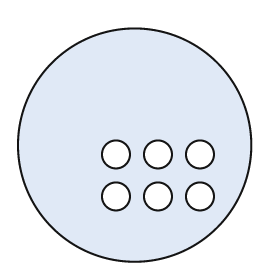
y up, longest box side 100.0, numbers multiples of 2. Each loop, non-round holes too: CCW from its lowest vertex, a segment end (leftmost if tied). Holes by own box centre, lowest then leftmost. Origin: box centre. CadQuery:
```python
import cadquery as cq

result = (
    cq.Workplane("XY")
    .moveTo(0.0, 0.0)
    .circle(50.0)
    .moveTo(-8.0, -22.0)
    .circle(6.0)
    .moveTo(10.0, -22.0)
    .circle(6.0)
    .moveTo(28.0, -22.0)
    .circle(6.0)
    .moveTo(-8.0, -4.0)
    .circle(6.0)
    .moveTo(10.0, -4.0)
    .circle(6.0)
    .moveTo(28.0, -4.0)
    .circle(6.0)
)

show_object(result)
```